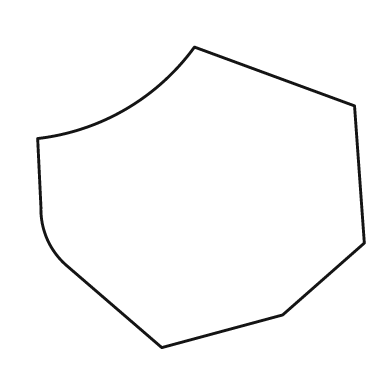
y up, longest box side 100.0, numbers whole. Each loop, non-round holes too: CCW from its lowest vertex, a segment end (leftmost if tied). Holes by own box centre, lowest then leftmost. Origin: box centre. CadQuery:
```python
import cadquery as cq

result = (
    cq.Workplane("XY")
    .moveTo(-12.0, -46.0)
    .lineTo(25.0, -36.0)
    .lineTo(50.0, -14.0)
    .lineTo(47.0, 28.0)
    .lineTo(-2.0, 46.0)
    .threePointArc((-23.0, 27.0), (-50.0, 18.0))
    .lineTo(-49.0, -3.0)
    .threePointArc((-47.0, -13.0), (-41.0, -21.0))
    .close()
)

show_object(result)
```